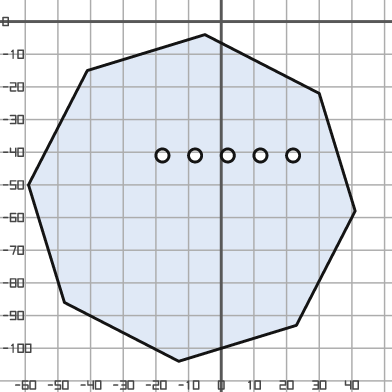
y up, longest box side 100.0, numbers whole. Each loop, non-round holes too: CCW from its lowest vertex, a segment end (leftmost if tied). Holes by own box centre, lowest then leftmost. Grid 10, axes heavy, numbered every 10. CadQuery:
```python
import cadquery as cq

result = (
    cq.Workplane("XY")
    .moveTo(-13.0, -104.0)
    .lineTo(23.0, -93.0)
    .lineTo(41.0, -58.0)
    .lineTo(30.0, -22.0)
    .lineTo(-5.0, -4.0)
    .lineTo(-41.0, -15.0)
    .lineTo(-59.0, -50.0)
    .lineTo(-48.0, -86.0)
    .close()
    .moveTo(-18.0, -41.0)
    .circle(2.0)
    .moveTo(-8.0, -41.0)
    .circle(2.0)
    .moveTo(2.0, -41.0)
    .circle(2.0)
    .moveTo(12.0, -41.0)
    .circle(2.0)
    .moveTo(22.0, -41.0)
    .circle(2.0)
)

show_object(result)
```